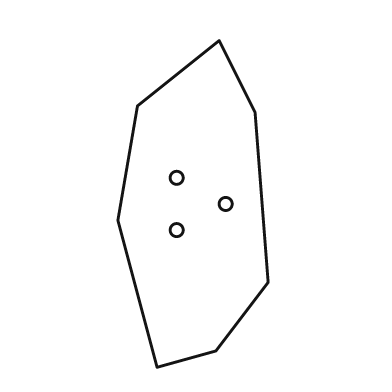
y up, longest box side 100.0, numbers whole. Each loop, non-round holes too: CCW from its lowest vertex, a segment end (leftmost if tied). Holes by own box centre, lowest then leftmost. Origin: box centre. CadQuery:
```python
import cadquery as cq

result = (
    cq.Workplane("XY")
    .moveTo(-11.0, -50.0)
    .lineTo(7.0, -45.0)
    .lineTo(23.0, -24.0)
    .lineTo(19.0, 28.0)
    .lineTo(8.0, 50.0)
    .lineTo(-17.0, 30.0)
    .lineTo(-23.0, -5.0)
    .close()
    .moveTo(-5.0, -8.0)
    .circle(2.0)
    .moveTo(10.0, 0.0)
    .circle(2.0)
    .moveTo(-5.0, 8.0)
    .circle(2.0)
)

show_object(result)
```